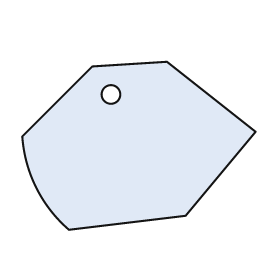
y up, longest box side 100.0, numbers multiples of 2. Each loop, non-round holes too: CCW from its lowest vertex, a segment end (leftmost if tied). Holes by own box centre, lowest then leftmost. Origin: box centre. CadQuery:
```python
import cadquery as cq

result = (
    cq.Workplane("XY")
    .moveTo(-30.0, -36.0)
    .lineTo(20.0, -30.0)
    .lineTo(50.0, 6.0)
    .lineTo(12.0, 36.0)
    .lineTo(-20.0, 34.0)
    .lineTo(-50.0, 4.0)
    .threePointArc((-44.0, -18.0), (-30.0, -36.0))
    .close()
    .moveTo(-12.0, 22.0)
    .circle(4.0)
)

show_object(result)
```